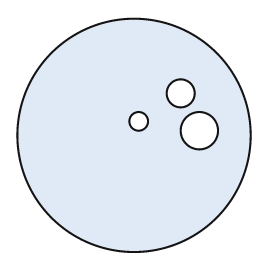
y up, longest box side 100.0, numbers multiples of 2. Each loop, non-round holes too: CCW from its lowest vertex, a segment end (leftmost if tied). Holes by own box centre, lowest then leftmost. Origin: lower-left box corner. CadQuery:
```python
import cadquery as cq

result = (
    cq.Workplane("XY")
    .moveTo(50.0, 50.0)
    .circle(50.0)
    .moveTo(78.0, 52.0)
    .circle(8.0)
    .moveTo(52.0, 56.0)
    .circle(4.0)
    .moveTo(70.0, 68.0)
    .circle(6.0)
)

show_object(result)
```